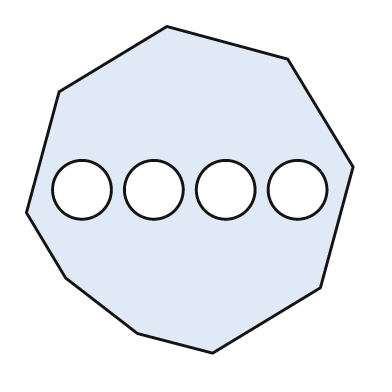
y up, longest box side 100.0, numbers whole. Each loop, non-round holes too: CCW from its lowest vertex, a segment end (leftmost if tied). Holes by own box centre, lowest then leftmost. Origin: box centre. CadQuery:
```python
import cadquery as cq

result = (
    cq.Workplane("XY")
    .moveTo(7.0, -50.0)
    .lineTo(40.0, -30.0)
    .lineTo(50.0, 7.0)
    .lineTo(30.0, 40.0)
    .lineTo(-7.0, 50.0)
    .lineTo(-40.0, 30.0)
    .lineTo(-50.0, -7.0)
    .lineTo(-38.0, -27.0)
    .lineTo(-16.0, -44.0)
    .close()
    .moveTo(-33.0, 0.0)
    .circle(9.0)
    .moveTo(-11.0, 0.0)
    .circle(9.0)
    .moveTo(11.0, 0.0)
    .circle(9.0)
    .moveTo(33.0, 0.0)
    .circle(9.0)
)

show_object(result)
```